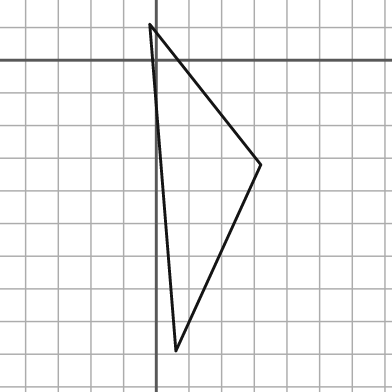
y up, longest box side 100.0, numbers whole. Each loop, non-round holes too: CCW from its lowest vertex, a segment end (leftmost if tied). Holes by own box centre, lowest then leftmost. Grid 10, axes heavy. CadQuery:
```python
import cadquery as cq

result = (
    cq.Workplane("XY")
    .moveTo(6.0, -89.0)
    .lineTo(32.0, -32.0)
    .lineTo(-2.0, 11.0)
    .close()
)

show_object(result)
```